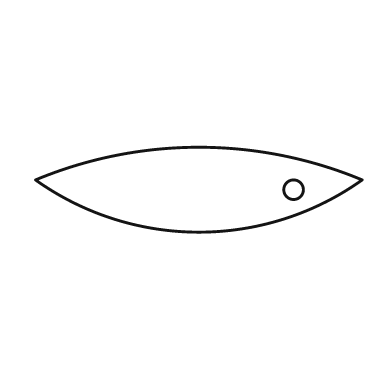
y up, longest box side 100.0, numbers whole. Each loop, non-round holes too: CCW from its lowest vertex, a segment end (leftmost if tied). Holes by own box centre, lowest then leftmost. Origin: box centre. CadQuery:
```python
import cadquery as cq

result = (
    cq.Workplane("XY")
    .moveTo(-50.0, 3.0)
    .threePointArc((0.0, -13.0), (50.0, 3.0))
    .threePointArc((0.0, 13.0), (-50.0, 3.0))
    .close()
    .moveTo(29.0, 0.0)
    .circle(3.0)
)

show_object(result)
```